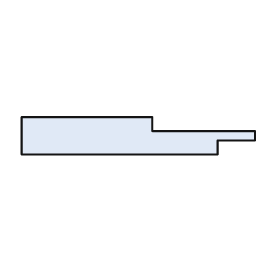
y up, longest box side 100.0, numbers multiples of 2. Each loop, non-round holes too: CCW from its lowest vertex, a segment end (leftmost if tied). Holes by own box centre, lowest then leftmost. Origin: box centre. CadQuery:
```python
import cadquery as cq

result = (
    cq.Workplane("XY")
    .moveTo(-50.0, -8.0)
    .lineTo(34.0, -8.0)
    .lineTo(34.0, -2.0)
    .lineTo(50.0, -2.0)
    .lineTo(50.0, 2.0)
    .lineTo(6.0, 2.0)
    .lineTo(6.0, 8.0)
    .lineTo(-50.0, 8.0)
    .close()
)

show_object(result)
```